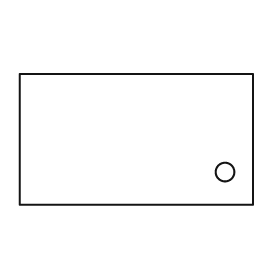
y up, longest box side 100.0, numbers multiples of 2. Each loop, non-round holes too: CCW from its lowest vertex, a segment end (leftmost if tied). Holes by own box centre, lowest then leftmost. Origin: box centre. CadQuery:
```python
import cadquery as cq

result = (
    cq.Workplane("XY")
    .moveTo(-50.0, -28.0)
    .lineTo(50.0, -28.0)
    .lineTo(50.0, 28.0)
    .lineTo(-50.0, 28.0)
    .close()
    .moveTo(38.0, -14.0)
    .circle(4.0)
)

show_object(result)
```